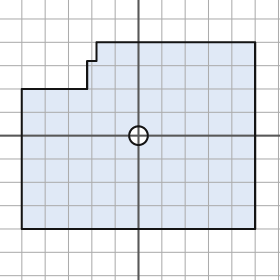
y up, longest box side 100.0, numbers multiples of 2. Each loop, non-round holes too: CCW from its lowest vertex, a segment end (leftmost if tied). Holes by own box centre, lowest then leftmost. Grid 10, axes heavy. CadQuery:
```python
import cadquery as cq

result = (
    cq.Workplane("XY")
    .moveTo(-50.0, -40.0)
    .lineTo(50.0, -40.0)
    .lineTo(50.0, 40.0)
    .lineTo(-18.0, 40.0)
    .lineTo(-18.0, 32.0)
    .lineTo(-22.0, 32.0)
    .lineTo(-22.0, 20.0)
    .lineTo(-50.0, 20.0)
    .close()
    .moveTo(0.0, 0.0)
    .circle(4.0)
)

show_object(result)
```